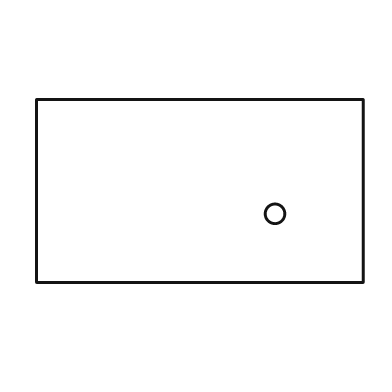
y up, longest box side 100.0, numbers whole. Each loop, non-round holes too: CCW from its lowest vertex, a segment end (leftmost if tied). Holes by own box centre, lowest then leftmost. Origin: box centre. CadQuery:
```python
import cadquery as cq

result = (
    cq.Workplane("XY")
    .moveTo(-50.0, -28.0)
    .lineTo(50.0, -28.0)
    .lineTo(50.0, 28.0)
    .lineTo(-50.0, 28.0)
    .close()
    .moveTo(23.0, -7.0)
    .circle(3.0)
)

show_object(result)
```